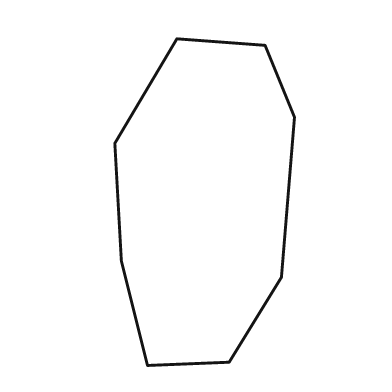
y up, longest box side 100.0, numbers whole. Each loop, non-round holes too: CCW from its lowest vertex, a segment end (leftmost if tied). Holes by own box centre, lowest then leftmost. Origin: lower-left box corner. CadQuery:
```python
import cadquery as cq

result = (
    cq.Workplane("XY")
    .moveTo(10.0, 0.0)
    .lineTo(35.0, 1.0)
    .lineTo(51.0, 27.0)
    .lineTo(55.0, 76.0)
    .lineTo(46.0, 98.0)
    .lineTo(19.0, 100.0)
    .lineTo(0.0, 68.0)
    .lineTo(2.0, 32.0)
    .close()
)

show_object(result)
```